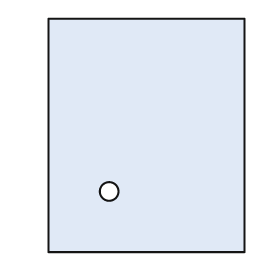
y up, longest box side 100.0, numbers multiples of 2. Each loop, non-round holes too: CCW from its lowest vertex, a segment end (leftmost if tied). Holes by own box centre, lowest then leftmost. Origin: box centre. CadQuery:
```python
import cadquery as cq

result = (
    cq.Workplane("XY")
    .moveTo(-42.0, -50.0)
    .lineTo(42.0, -50.0)
    .lineTo(42.0, 50.0)
    .lineTo(-42.0, 50.0)
    .close()
    .moveTo(-16.0, -24.0)
    .circle(4.0)
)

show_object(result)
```